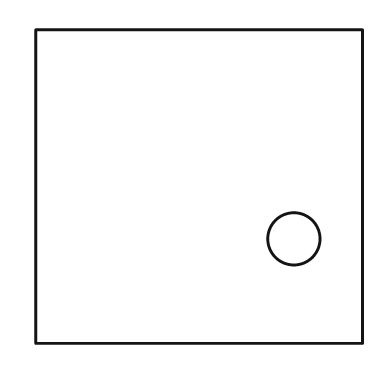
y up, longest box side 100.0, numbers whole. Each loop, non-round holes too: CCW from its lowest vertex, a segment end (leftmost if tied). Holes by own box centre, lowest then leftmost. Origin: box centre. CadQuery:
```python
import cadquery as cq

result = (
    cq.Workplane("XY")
    .moveTo(-50.0, -48.0)
    .lineTo(50.0, -48.0)
    .lineTo(50.0, 48.0)
    .lineTo(-50.0, 48.0)
    .close()
    .moveTo(29.0, -16.0)
    .circle(8.0)
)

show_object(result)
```